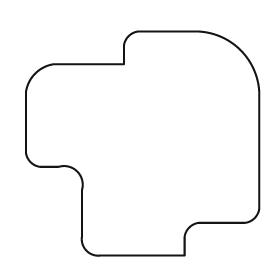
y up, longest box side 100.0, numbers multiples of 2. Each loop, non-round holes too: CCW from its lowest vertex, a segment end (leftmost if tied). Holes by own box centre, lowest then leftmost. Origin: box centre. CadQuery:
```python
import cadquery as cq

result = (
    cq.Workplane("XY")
    .moveTo(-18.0, -48.0)
    .lineTo(18.0, -48.0)
    .lineTo(18.0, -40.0)
    .threePointArc((20.0, -36.0), (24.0, -34.0))
    .lineTo(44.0, -34.0)
    .threePointArc((48.0, -32.0), (50.0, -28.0))
    .lineTo(50.0, 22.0)
    .threePointArc((42.0, 40.0), (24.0, 48.0))
    .lineTo(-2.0, 48.0)
    .threePointArc((-6.0, 46.0), (-8.0, 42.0))
    .lineTo(-8.0, 34.0)
    .lineTo(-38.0, 34.0)
    .threePointArc((-46.0, 30.0), (-50.0, 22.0))
    .lineTo(-50.0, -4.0)
    .threePointArc((-48.0, -8.0), (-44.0, -10.0))
    .lineTo(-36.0, -10.0)
    .threePointArc((-28.0, -12.0), (-26.0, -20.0))
    .lineTo(-26.0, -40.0)
    .threePointArc((-24.0, -46.0), (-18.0, -48.0))
    .close()
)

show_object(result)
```